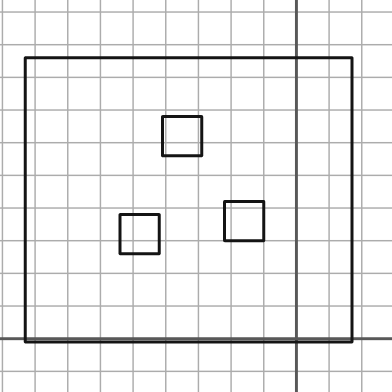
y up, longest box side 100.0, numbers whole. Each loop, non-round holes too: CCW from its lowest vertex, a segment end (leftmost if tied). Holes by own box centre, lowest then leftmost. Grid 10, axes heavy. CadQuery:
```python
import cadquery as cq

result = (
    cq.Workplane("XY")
    .moveTo(-83.0, -1.0)
    .lineTo(17.0, -1.0)
    .lineTo(17.0, 86.0)
    .lineTo(-83.0, 86.0)
    .close()
    .moveTo(-54.0, 26.0)
    .lineTo(-42.0, 26.0)
    .lineTo(-42.0, 38.0)
    .lineTo(-54.0, 38.0)
    .close()
    .moveTo(-22.0, 30.0)
    .lineTo(-10.0, 30.0)
    .lineTo(-10.0, 42.0)
    .lineTo(-22.0, 42.0)
    .close()
    .moveTo(-41.0, 56.0)
    .lineTo(-29.0, 56.0)
    .lineTo(-29.0, 68.0)
    .lineTo(-41.0, 68.0)
    .close()
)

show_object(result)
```